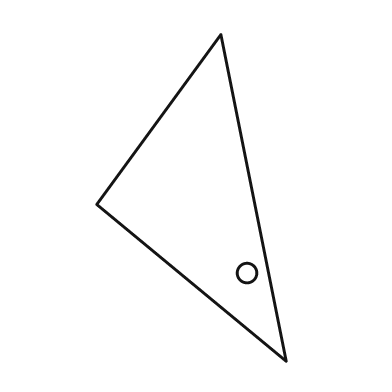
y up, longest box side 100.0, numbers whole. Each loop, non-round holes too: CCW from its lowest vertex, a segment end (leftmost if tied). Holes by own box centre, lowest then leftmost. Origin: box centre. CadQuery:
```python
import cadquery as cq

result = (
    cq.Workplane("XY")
    .moveTo(29.0, -50.0)
    .lineTo(9.0, 50.0)
    .lineTo(-29.0, -2.0)
    .close()
    .moveTo(17.0, -23.0)
    .circle(3.0)
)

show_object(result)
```